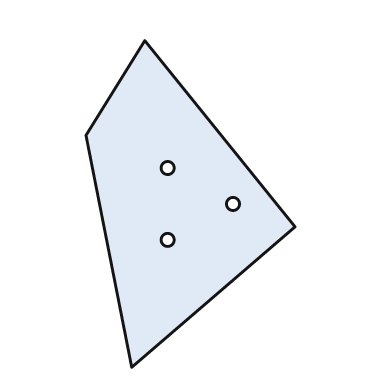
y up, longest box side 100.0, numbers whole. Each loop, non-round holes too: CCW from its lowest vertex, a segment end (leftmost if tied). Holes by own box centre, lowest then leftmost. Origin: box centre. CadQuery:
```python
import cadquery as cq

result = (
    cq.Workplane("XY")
    .moveTo(-18.0, -50.0)
    .lineTo(32.0, -7.0)
    .lineTo(-14.0, 50.0)
    .lineTo(-32.0, 21.0)
    .close()
    .moveTo(-7.0, -11.0)
    .circle(2.0)
    .moveTo(13.0, 0.0)
    .circle(2.0)
    .moveTo(-7.0, 11.0)
    .circle(2.0)
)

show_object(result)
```